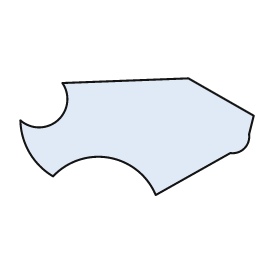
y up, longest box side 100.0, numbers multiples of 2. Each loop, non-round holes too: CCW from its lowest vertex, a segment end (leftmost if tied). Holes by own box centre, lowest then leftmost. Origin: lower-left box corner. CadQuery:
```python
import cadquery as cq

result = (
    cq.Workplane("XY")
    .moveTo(58.0, 0.0)
    .lineTo(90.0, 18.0)
    .threePointArc((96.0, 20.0), (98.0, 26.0))
    .lineTo(100.0, 34.0)
    .lineTo(72.0, 50.0)
    .lineTo(18.0, 48.0)
    .threePointArc((16.0, 32.0), (0.0, 32.0))
    .threePointArc((4.0, 18.0), (14.0, 8.0))
    .threePointArc((38.0, 16.0), (58.0, 0.0))
    .close()
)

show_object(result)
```